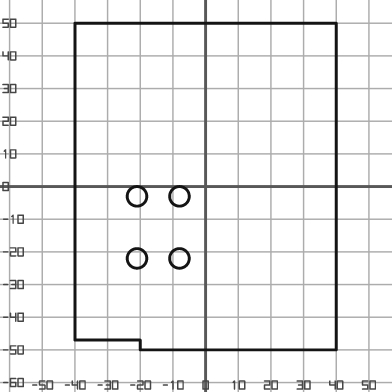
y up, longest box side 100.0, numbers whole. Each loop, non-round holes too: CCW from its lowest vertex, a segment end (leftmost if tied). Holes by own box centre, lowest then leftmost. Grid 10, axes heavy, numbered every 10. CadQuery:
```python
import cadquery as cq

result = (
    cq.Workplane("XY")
    .moveTo(-20.0, -50.0)
    .lineTo(40.0, -50.0)
    .lineTo(40.0, 50.0)
    .lineTo(-40.0, 50.0)
    .lineTo(-40.0, -47.0)
    .lineTo(-20.0, -47.0)
    .close()
    .moveTo(-21.0, -22.0)
    .circle(3.0)
    .moveTo(-8.0, -22.0)
    .circle(3.0)
    .moveTo(-21.0, -3.0)
    .circle(3.0)
    .moveTo(-8.0, -3.0)
    .circle(3.0)
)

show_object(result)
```